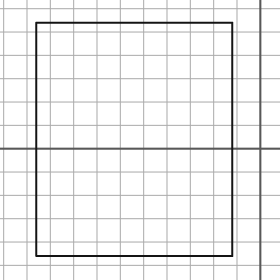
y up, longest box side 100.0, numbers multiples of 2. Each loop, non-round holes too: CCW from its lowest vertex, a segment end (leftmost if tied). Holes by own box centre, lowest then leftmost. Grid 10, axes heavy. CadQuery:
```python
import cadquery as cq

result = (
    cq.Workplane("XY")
    .moveTo(-96.0, -46.0)
    .lineTo(-12.0, -46.0)
    .lineTo(-12.0, 54.0)
    .lineTo(-96.0, 54.0)
    .close()
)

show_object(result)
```